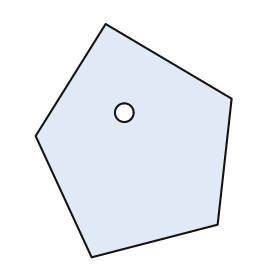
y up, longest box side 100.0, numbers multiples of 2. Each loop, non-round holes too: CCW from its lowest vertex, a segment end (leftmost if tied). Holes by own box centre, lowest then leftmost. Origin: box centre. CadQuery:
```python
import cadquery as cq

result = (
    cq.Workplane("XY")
    .moveTo(-18.0, -50.0)
    .lineTo(36.0, -36.0)
    .lineTo(42.0, 18.0)
    .lineTo(-12.0, 50.0)
    .lineTo(-42.0, 2.0)
    .close()
    .moveTo(-4.0, 12.0)
    .circle(4.0)
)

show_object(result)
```